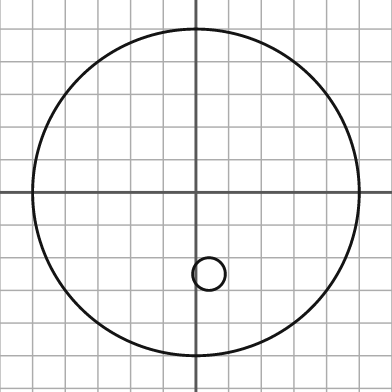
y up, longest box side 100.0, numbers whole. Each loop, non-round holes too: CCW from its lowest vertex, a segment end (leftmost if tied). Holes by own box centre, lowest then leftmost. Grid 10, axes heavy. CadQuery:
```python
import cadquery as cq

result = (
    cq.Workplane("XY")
    .moveTo(0.0, 0.0)
    .circle(50.0)
    .moveTo(4.0, -25.0)
    .circle(5.0)
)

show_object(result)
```